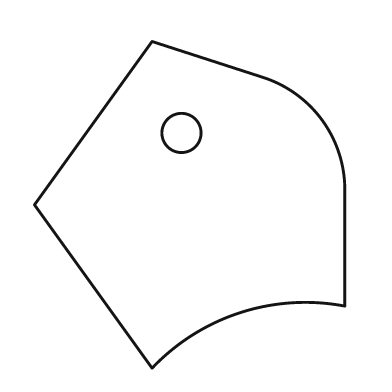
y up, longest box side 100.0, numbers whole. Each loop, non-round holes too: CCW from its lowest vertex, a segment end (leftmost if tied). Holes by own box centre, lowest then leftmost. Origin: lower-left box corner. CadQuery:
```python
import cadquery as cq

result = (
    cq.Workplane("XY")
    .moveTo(36.0, 0.0)
    .threePointArc((63.0, 17.0), (95.0, 19.0))
    .lineTo(95.0, 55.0)
    .threePointArc((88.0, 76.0), (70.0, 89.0))
    .lineTo(36.0, 100.0)
    .lineTo(0.0, 50.0)
    .close()
    .moveTo(45.0, 72.0)
    .circle(6.0)
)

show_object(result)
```